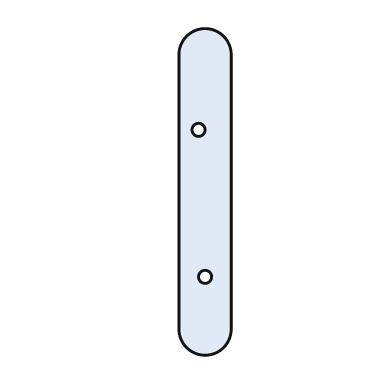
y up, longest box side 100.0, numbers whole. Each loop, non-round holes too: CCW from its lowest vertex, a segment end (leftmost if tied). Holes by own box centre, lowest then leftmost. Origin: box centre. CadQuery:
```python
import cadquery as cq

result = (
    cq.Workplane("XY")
    .moveTo(-8.0, -42.0)
    .threePointArc((0.0, -50.0), (8.0, -42.0))
    .lineTo(8.0, 42.0)
    .threePointArc((0.0, 50.0), (-8.0, 42.0))
    .close()
    .moveTo(0.0, -26.0)
    .circle(2.0)
    .moveTo(-2.0, 19.0)
    .circle(2.0)
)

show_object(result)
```